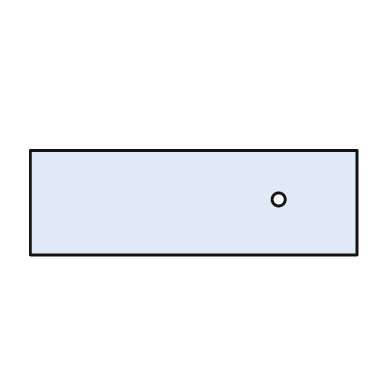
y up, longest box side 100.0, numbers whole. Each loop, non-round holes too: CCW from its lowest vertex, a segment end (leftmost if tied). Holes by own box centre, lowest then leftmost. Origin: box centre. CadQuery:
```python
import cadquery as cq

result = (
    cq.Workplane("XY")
    .moveTo(-50.0, -16.0)
    .lineTo(50.0, -16.0)
    .lineTo(50.0, 16.0)
    .lineTo(-50.0, 16.0)
    .close()
    .moveTo(26.0, 1.0)
    .circle(2.0)
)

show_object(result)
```